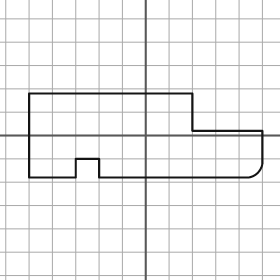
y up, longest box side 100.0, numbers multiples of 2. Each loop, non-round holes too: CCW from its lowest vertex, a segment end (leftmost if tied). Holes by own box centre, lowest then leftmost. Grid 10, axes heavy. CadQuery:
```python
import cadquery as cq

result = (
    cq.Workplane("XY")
    .moveTo(-50.0, -18.0)
    .lineTo(-30.0, -18.0)
    .lineTo(-30.0, -10.0)
    .lineTo(-20.0, -10.0)
    .lineTo(-20.0, -18.0)
    .lineTo(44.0, -18.0)
    .threePointArc((48.0, -16.0), (50.0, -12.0))
    .lineTo(50.0, 2.0)
    .lineTo(20.0, 2.0)
    .lineTo(20.0, 18.0)
    .lineTo(-50.0, 18.0)
    .close()
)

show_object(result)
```